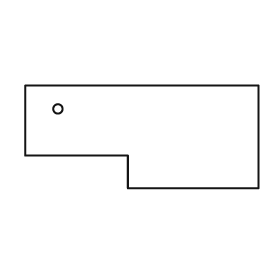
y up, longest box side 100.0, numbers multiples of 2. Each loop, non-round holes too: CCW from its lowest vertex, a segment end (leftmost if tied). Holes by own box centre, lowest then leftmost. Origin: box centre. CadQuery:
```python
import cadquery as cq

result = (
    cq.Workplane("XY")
    .moveTo(-6.0, -22.0)
    .lineTo(50.0, -22.0)
    .lineTo(50.0, 22.0)
    .lineTo(-50.0, 22.0)
    .lineTo(-50.0, -8.0)
    .lineTo(-6.0, -8.0)
    .close()
    .moveTo(-36.0, 12.0)
    .circle(2.0)
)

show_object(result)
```